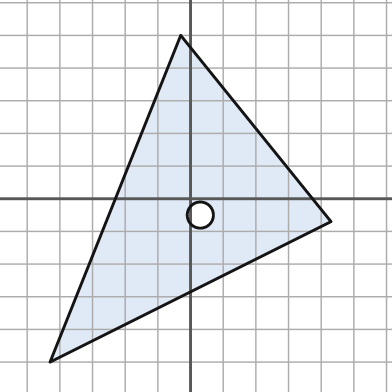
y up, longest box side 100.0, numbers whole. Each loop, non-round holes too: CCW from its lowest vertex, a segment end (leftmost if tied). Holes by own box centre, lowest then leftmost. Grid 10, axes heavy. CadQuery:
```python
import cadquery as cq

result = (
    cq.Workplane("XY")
    .moveTo(-43.0, -50.0)
    .lineTo(43.0, -7.0)
    .lineTo(-3.0, 50.0)
    .close()
    .moveTo(3.0, -5.0)
    .circle(4.0)
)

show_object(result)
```